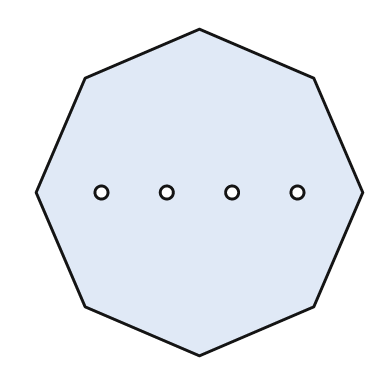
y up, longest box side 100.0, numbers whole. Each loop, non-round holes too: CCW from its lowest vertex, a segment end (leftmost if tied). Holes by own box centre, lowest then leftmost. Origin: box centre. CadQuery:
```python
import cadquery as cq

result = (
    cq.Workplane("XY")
    .moveTo(0.0, -50.0)
    .lineTo(35.0, -35.0)
    .lineTo(50.0, 0.0)
    .lineTo(35.0, 35.0)
    .lineTo(0.0, 50.0)
    .lineTo(-35.0, 35.0)
    .lineTo(-50.0, 0.0)
    .lineTo(-35.0, -35.0)
    .close()
    .moveTo(-30.0, 0.0)
    .circle(2.0)
    .moveTo(-10.0, 0.0)
    .circle(2.0)
    .moveTo(10.0, 0.0)
    .circle(2.0)
    .moveTo(30.0, 0.0)
    .circle(2.0)
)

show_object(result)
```